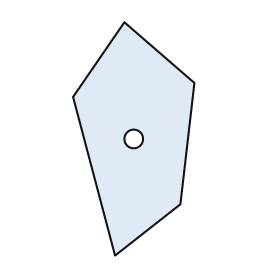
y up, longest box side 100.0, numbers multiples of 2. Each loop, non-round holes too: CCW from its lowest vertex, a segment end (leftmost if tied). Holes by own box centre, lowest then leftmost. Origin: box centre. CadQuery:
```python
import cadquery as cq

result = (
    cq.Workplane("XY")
    .moveTo(-8.0, -50.0)
    .lineTo(20.0, -28.0)
    .lineTo(26.0, 24.0)
    .lineTo(-4.0, 50.0)
    .lineTo(-26.0, 18.0)
    .close()
    .moveTo(0.0, 0.0)
    .circle(4.0)
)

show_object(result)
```